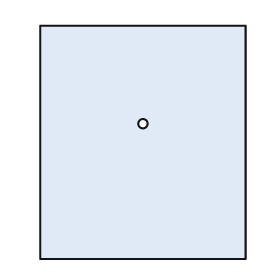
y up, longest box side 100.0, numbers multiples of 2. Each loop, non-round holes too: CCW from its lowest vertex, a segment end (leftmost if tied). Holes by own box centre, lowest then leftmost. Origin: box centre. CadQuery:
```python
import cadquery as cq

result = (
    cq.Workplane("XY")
    .moveTo(-44.0, -50.0)
    .lineTo(44.0, -50.0)
    .lineTo(44.0, 50.0)
    .lineTo(-44.0, 50.0)
    .close()
    .moveTo(0.0, 8.0)
    .circle(2.0)
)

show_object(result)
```